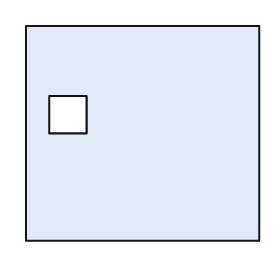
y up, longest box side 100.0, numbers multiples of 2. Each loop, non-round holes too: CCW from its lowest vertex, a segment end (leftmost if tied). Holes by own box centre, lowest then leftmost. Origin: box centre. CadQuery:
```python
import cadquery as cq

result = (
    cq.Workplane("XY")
    .moveTo(-50.0, -46.0)
    .lineTo(50.0, -46.0)
    .lineTo(50.0, 46.0)
    .lineTo(-50.0, 46.0)
    .close()
    .moveTo(-40.0, 0.0)
    .lineTo(-24.0, 0.0)
    .lineTo(-24.0, 16.0)
    .lineTo(-40.0, 16.0)
    .close()
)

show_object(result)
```